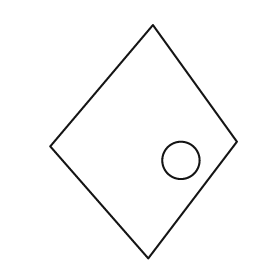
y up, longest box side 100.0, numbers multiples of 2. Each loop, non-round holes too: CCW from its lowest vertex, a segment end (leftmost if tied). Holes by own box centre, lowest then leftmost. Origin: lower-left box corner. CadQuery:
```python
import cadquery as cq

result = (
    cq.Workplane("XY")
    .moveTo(42.0, 0.0)
    .lineTo(80.0, 50.0)
    .lineTo(44.0, 100.0)
    .lineTo(0.0, 48.0)
    .close()
    .moveTo(56.0, 42.0)
    .circle(8.0)
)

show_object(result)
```